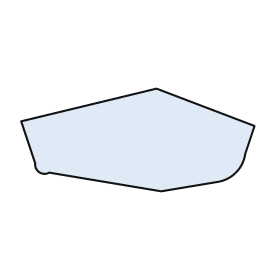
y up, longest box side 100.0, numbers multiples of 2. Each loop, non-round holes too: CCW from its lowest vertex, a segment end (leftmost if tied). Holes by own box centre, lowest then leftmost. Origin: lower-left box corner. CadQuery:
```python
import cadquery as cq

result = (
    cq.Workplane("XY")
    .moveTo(60.0, 0.0)
    .lineTo(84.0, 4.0)
    .threePointArc((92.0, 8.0), (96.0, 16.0))
    .lineTo(100.0, 28.0)
    .lineTo(58.0, 44.0)
    .lineTo(0.0, 30.0)
    .lineTo(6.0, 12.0)
    .threePointArc((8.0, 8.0), (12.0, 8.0))
    .close()
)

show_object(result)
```